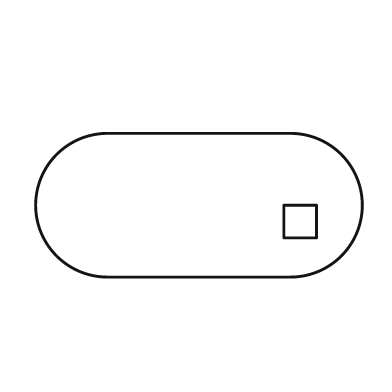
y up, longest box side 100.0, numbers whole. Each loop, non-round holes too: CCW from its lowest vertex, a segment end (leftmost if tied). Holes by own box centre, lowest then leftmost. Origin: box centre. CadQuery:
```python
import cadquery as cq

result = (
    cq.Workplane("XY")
    .moveTo(-28.0, -22.0)
    .lineTo(28.0, -22.0)
    .threePointArc((50.0, 0.0), (28.0, 22.0))
    .lineTo(-28.0, 22.0)
    .threePointArc((-50.0, 0.0), (-28.0, -22.0))
    .close()
    .moveTo(26.0, -10.0)
    .lineTo(36.0, -10.0)
    .lineTo(36.0, 0.0)
    .lineTo(26.0, 0.0)
    .close()
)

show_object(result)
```